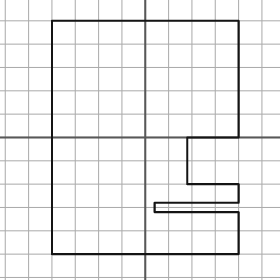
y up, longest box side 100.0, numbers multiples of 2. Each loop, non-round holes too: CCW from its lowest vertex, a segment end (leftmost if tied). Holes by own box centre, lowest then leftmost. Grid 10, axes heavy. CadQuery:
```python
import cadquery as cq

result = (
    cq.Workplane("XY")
    .moveTo(-40.0, -50.0)
    .lineTo(40.0, -50.0)
    .lineTo(40.0, -32.0)
    .lineTo(4.0, -32.0)
    .lineTo(4.0, -28.0)
    .lineTo(40.0, -28.0)
    .lineTo(40.0, -20.0)
    .lineTo(18.0, -20.0)
    .lineTo(18.0, 0.0)
    .lineTo(40.0, 0.0)
    .lineTo(40.0, 50.0)
    .lineTo(-40.0, 50.0)
    .close()
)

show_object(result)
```